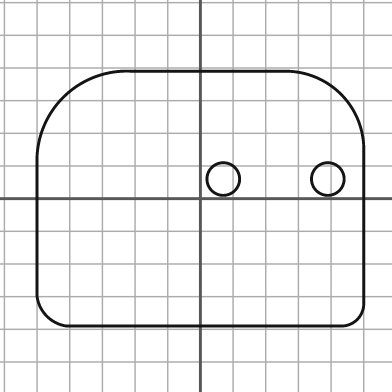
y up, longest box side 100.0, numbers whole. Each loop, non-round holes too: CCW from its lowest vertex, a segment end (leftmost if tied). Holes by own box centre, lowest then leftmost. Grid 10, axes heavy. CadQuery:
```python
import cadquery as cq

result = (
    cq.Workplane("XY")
    .moveTo(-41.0, -39.0)
    .lineTo(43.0, -39.0)
    .threePointArc((48.0, -37.0), (50.0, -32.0))
    .lineTo(50.0, 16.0)
    .threePointArc((43.0, 32.0), (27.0, 39.0))
    .lineTo(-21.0, 39.0)
    .threePointArc((-42.0, 31.0), (-50.0, 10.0))
    .lineTo(-50.0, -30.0)
    .threePointArc((-47.0, -36.0), (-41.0, -39.0))
    .close()
    .moveTo(7.0, 6.0)
    .circle(5.0)
    .moveTo(39.0, 6.0)
    .circle(5.0)
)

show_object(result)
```